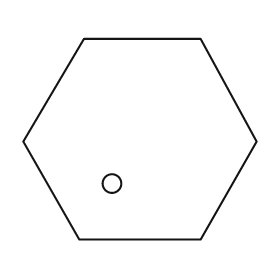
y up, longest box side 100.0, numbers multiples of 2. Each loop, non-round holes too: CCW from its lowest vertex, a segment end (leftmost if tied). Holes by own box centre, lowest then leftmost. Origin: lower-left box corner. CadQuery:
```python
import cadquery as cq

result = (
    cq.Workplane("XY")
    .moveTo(24.0, 0.0)
    .lineTo(76.0, 0.0)
    .lineTo(100.0, 42.0)
    .lineTo(76.0, 86.0)
    .lineTo(26.0, 86.0)
    .lineTo(0.0, 42.0)
    .close()
    .moveTo(38.0, 24.0)
    .circle(4.0)
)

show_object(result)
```